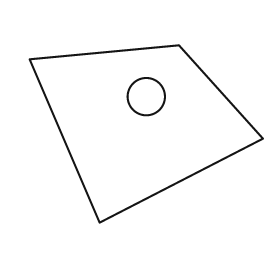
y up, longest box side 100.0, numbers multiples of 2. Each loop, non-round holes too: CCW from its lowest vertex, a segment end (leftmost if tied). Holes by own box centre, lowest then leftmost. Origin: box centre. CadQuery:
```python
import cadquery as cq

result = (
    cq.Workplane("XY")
    .moveTo(-20.0, -38.0)
    .lineTo(50.0, -2.0)
    .lineTo(14.0, 38.0)
    .lineTo(-50.0, 32.0)
    .close()
    .moveTo(0.0, 16.0)
    .circle(8.0)
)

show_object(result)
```